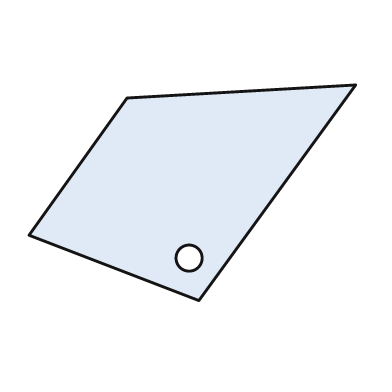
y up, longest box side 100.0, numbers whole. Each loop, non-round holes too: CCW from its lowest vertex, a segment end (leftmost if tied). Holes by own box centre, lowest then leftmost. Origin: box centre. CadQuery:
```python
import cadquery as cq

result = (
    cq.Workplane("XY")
    .moveTo(2.0, -33.0)
    .lineTo(50.0, 33.0)
    .lineTo(-20.0, 29.0)
    .lineTo(-50.0, -13.0)
    .close()
    .moveTo(-1.0, -20.0)
    .circle(4.0)
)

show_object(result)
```